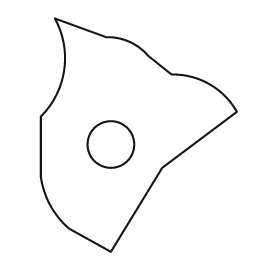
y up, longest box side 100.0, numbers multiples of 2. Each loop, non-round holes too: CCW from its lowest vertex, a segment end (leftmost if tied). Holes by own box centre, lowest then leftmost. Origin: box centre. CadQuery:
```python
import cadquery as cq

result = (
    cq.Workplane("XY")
    .moveTo(-12.0, -50.0)
    .lineTo(10.0, -14.0)
    .lineTo(42.0, 10.0)
    .threePointArc((30.0, 22.0), (14.0, 26.0))
    .lineTo(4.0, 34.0)
    .threePointArc((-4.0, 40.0), (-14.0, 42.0))
    .lineTo(-36.0, 50.0)
    .threePointArc((-32.0, 28.0), (-42.0, 8.0))
    .lineTo(-42.0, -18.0)
    .threePointArc((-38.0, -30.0), (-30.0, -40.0))
    .close()
    .moveTo(-12.0, -4.0)
    .circle(10.0)
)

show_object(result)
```